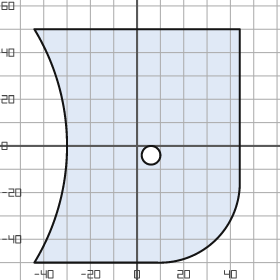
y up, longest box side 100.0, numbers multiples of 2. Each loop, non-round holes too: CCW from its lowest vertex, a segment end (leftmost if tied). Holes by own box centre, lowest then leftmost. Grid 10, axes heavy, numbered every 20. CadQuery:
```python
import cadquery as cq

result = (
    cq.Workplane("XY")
    .moveTo(-44.0, -50.0)
    .lineTo(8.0, -50.0)
    .threePointArc((34.0, -40.0), (44.0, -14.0))
    .lineTo(44.0, 50.0)
    .lineTo(-44.0, 50.0)
    .threePointArc((-30.0, 0.0), (-44.0, -50.0))
    .close()
    .moveTo(6.0, -4.0)
    .circle(4.0)
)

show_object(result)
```